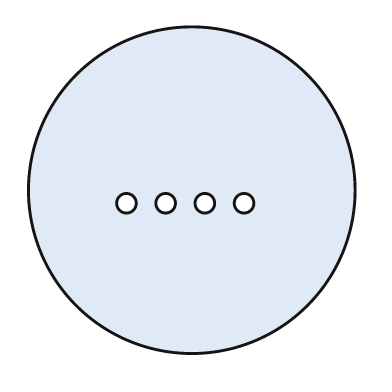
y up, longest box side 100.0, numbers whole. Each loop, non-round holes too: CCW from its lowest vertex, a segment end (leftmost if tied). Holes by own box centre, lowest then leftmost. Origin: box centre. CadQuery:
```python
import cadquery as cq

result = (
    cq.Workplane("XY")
    .moveTo(0.0, 0.0)
    .circle(50.0)
    .moveTo(-20.0, -4.0)
    .circle(3.0)
    .moveTo(-8.0, -4.0)
    .circle(3.0)
    .moveTo(4.0, -4.0)
    .circle(3.0)
    .moveTo(16.0, -4.0)
    .circle(3.0)
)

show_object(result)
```